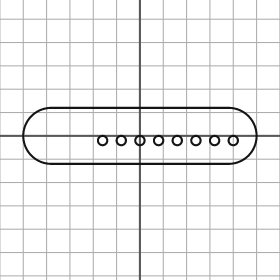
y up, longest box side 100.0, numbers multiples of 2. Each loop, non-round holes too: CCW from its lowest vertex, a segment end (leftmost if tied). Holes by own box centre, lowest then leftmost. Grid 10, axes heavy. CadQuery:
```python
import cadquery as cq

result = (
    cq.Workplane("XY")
    .moveTo(-38.0, -12.0)
    .lineTo(38.0, -12.0)
    .threePointArc((50.0, 0.0), (38.0, 12.0))
    .lineTo(-38.0, 12.0)
    .threePointArc((-50.0, 0.0), (-38.0, -12.0))
    .close()
    .moveTo(-16.0, -2.0)
    .circle(2.0)
    .moveTo(-8.0, -2.0)
    .circle(2.0)
    .moveTo(0.0, -2.0)
    .circle(2.0)
    .moveTo(8.0, -2.0)
    .circle(2.0)
    .moveTo(16.0, -2.0)
    .circle(2.0)
    .moveTo(24.0, -2.0)
    .circle(2.0)
    .moveTo(32.0, -2.0)
    .circle(2.0)
    .moveTo(40.0, -2.0)
    .circle(2.0)
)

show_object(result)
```